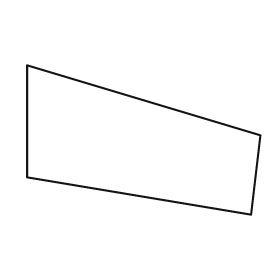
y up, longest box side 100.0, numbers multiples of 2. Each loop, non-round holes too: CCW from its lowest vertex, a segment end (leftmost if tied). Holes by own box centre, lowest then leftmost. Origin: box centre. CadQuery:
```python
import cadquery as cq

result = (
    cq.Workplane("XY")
    .moveTo(46.0, -32.0)
    .lineTo(50.0, 2.0)
    .lineTo(-50.0, 32.0)
    .lineTo(-50.0, -16.0)
    .close()
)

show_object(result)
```